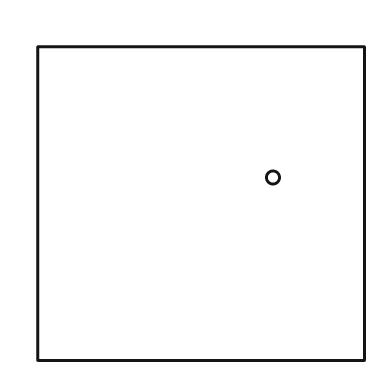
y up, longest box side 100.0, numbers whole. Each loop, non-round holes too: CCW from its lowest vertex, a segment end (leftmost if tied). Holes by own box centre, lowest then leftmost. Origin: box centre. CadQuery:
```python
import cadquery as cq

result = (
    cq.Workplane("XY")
    .moveTo(-50.0, -48.0)
    .lineTo(50.0, -48.0)
    .lineTo(50.0, 48.0)
    .lineTo(-50.0, 48.0)
    .close()
    .moveTo(22.0, 8.0)
    .circle(2.0)
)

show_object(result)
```